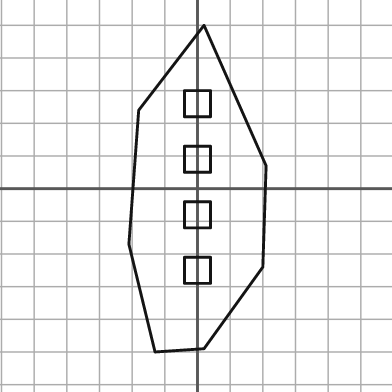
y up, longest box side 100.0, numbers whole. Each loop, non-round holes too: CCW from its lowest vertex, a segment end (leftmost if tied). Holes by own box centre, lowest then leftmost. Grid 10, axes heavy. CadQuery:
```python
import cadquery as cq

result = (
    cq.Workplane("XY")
    .moveTo(-13.0, -50.0)
    .lineTo(2.0, -49.0)
    .lineTo(20.0, -24.0)
    .lineTo(21.0, 7.0)
    .lineTo(2.0, 50.0)
    .lineTo(-18.0, 24.0)
    .lineTo(-21.0, -17.0)
    .close()
    .moveTo(-4.0, -29.0)
    .lineTo(4.0, -29.0)
    .lineTo(4.0, -21.0)
    .lineTo(-4.0, -21.0)
    .close()
    .moveTo(-4.0, -12.0)
    .lineTo(4.0, -12.0)
    .lineTo(4.0, -4.0)
    .lineTo(-4.0, -4.0)
    .close()
    .moveTo(-4.0, 5.0)
    .lineTo(4.0, 5.0)
    .lineTo(4.0, 13.0)
    .lineTo(-4.0, 13.0)
    .close()
    .moveTo(-4.0, 22.0)
    .lineTo(4.0, 22.0)
    .lineTo(4.0, 30.0)
    .lineTo(-4.0, 30.0)
    .close()
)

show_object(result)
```